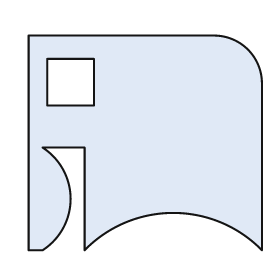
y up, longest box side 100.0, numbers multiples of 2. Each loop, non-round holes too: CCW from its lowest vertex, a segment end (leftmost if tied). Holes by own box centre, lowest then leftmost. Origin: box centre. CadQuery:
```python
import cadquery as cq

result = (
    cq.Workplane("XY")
    .moveTo(-50.0, -46.0)
    .lineTo(-44.0, -46.0)
    .threePointArc((-32.0, -24.0), (-44.0, -2.0))
    .lineTo(-26.0, -2.0)
    .lineTo(-26.0, -46.0)
    .threePointArc((12.0, -30.0), (50.0, -46.0))
    .lineTo(50.0, 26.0)
    .threePointArc((44.0, 40.0), (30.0, 46.0))
    .lineTo(-50.0, 46.0)
    .close()
    .moveTo(-42.0, 16.0)
    .lineTo(-22.0, 16.0)
    .lineTo(-22.0, 36.0)
    .lineTo(-42.0, 36.0)
    .close()
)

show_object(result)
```